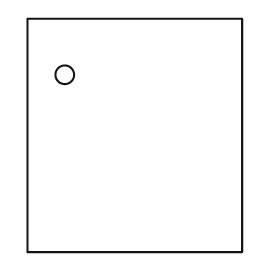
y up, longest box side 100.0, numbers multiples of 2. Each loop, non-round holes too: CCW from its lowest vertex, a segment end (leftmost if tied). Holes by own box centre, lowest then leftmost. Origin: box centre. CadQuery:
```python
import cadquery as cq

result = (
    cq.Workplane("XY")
    .moveTo(-46.0, -50.0)
    .lineTo(46.0, -50.0)
    .lineTo(46.0, 50.0)
    .lineTo(-46.0, 50.0)
    .close()
    .moveTo(-30.0, 26.0)
    .circle(4.0)
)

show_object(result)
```